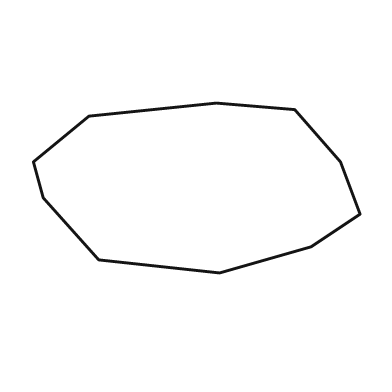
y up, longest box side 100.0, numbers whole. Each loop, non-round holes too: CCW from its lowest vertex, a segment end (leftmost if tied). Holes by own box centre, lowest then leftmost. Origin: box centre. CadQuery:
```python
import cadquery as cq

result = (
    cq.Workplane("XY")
    .moveTo(7.0, -26.0)
    .lineTo(35.0, -18.0)
    .lineTo(50.0, -8.0)
    .lineTo(44.0, 8.0)
    .lineTo(30.0, 24.0)
    .lineTo(6.0, 26.0)
    .lineTo(-33.0, 22.0)
    .lineTo(-50.0, 8.0)
    .lineTo(-47.0, -3.0)
    .lineTo(-30.0, -22.0)
    .close()
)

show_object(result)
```